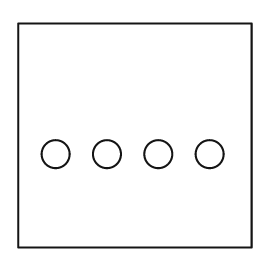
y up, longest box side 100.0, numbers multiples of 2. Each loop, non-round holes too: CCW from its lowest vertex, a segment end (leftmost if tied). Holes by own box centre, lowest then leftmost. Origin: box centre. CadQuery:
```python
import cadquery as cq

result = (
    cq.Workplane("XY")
    .moveTo(-50.0, -48.0)
    .lineTo(50.0, -48.0)
    .lineTo(50.0, 48.0)
    .lineTo(-50.0, 48.0)
    .close()
    .moveTo(-34.0, -8.0)
    .circle(6.0)
    .moveTo(-12.0, -8.0)
    .circle(6.0)
    .moveTo(10.0, -8.0)
    .circle(6.0)
    .moveTo(32.0, -8.0)
    .circle(6.0)
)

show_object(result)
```